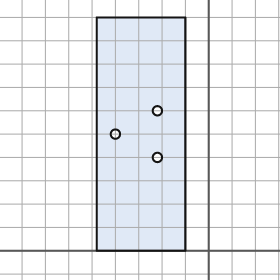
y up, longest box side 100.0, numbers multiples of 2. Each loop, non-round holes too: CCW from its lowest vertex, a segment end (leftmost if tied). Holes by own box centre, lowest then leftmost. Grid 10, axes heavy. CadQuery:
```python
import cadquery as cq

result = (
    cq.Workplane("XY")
    .moveTo(-48.0, 0.0)
    .lineTo(-10.0, 0.0)
    .lineTo(-10.0, 100.0)
    .lineTo(-48.0, 100.0)
    .close()
    .moveTo(-22.0, 40.0)
    .circle(2.0)
    .moveTo(-40.0, 50.0)
    .circle(2.0)
    .moveTo(-22.0, 60.0)
    .circle(2.0)
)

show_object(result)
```